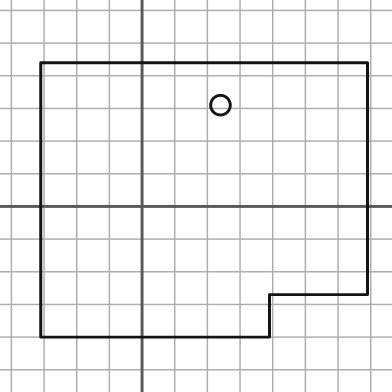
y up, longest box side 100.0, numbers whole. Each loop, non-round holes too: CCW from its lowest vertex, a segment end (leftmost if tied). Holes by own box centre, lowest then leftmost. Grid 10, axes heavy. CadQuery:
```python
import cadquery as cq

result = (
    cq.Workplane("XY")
    .moveTo(-31.0, -40.0)
    .lineTo(39.0, -40.0)
    .lineTo(39.0, -27.0)
    .lineTo(69.0, -27.0)
    .lineTo(69.0, 44.0)
    .lineTo(-31.0, 44.0)
    .close()
    .moveTo(24.0, 31.0)
    .circle(3.0)
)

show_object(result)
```